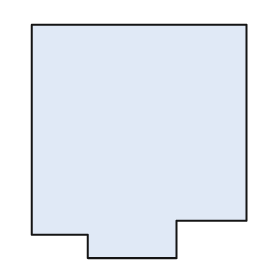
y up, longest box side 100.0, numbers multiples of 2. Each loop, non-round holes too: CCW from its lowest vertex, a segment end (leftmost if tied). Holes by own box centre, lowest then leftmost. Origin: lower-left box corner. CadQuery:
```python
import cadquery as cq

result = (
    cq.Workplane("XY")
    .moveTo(24.0, 0.0)
    .lineTo(62.0, 0.0)
    .lineTo(62.0, 16.0)
    .lineTo(92.0, 16.0)
    .lineTo(92.0, 100.0)
    .lineTo(0.0, 100.0)
    .lineTo(0.0, 10.0)
    .lineTo(24.0, 10.0)
    .close()
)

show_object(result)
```